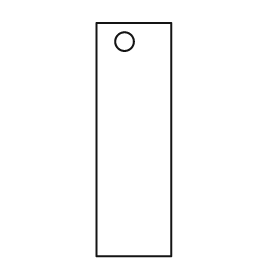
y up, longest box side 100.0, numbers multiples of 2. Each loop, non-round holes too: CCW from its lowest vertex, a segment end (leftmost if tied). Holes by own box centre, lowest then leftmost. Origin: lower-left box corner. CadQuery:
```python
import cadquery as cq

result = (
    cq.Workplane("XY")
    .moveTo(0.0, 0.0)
    .lineTo(32.0, 0.0)
    .lineTo(32.0, 100.0)
    .lineTo(0.0, 100.0)
    .close()
    .moveTo(12.0, 92.0)
    .circle(4.0)
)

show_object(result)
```